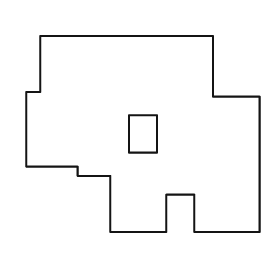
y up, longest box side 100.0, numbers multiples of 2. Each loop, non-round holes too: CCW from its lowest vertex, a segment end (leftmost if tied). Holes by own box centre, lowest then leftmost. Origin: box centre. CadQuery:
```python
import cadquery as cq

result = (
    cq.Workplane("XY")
    .moveTo(-14.0, -42.0)
    .lineTo(10.0, -42.0)
    .lineTo(10.0, -26.0)
    .lineTo(22.0, -26.0)
    .lineTo(22.0, -42.0)
    .lineTo(50.0, -42.0)
    .lineTo(50.0, 16.0)
    .lineTo(30.0, 16.0)
    .lineTo(30.0, 42.0)
    .lineTo(-44.0, 42.0)
    .lineTo(-44.0, 18.0)
    .lineTo(-50.0, 18.0)
    .lineTo(-50.0, -14.0)
    .lineTo(-28.0, -14.0)
    .lineTo(-28.0, -18.0)
    .lineTo(-14.0, -18.0)
    .close()
    .moveTo(-6.0, -8.0)
    .lineTo(6.0, -8.0)
    .lineTo(6.0, 8.0)
    .lineTo(-6.0, 8.0)
    .close()
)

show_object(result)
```